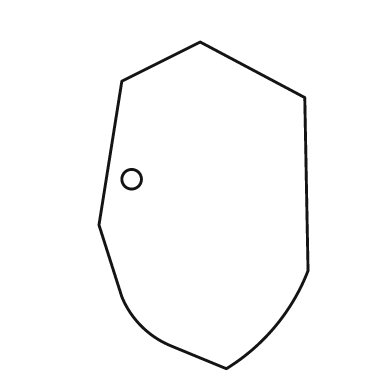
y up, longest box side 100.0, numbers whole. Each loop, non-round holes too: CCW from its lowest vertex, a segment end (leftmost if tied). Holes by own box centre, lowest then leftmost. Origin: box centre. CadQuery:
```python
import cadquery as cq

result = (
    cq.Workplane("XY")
    .moveTo(7.0, -50.0)
    .threePointArc((22.0, -37.0), (32.0, -20.0))
    .lineTo(31.0, 33.0)
    .lineTo(-1.0, 50.0)
    .lineTo(-25.0, 38.0)
    .lineTo(-32.0, -6.0)
    .lineTo(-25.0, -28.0)
    .threePointArc((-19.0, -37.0), (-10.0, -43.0))
    .close()
    .moveTo(-22.0, 8.0)
    .circle(3.0)
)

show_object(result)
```